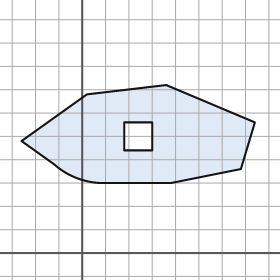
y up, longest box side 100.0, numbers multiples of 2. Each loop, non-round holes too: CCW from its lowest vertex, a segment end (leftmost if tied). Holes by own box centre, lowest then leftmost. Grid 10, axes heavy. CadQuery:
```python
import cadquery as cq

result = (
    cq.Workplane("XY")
    .moveTo(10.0, 30.0)
    .lineTo(38.0, 30.0)
    .lineTo(68.0, 36.0)
    .lineTo(74.0, 56.0)
    .lineTo(36.0, 72.0)
    .lineTo(2.0, 68.0)
    .lineTo(-26.0, 48.0)
    .lineTo(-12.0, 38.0)
    .threePointArc((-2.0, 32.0), (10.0, 30.0))
    .close()
    .moveTo(18.0, 44.0)
    .lineTo(30.0, 44.0)
    .lineTo(30.0, 56.0)
    .lineTo(18.0, 56.0)
    .close()
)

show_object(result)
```